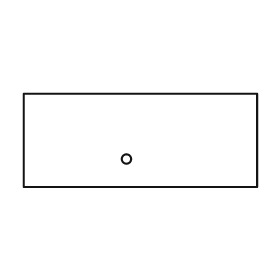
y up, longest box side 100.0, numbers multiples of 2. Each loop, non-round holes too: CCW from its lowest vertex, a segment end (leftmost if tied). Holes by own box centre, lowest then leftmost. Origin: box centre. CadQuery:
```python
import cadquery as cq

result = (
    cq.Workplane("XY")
    .moveTo(-50.0, -20.0)
    .lineTo(50.0, -20.0)
    .lineTo(50.0, 20.0)
    .lineTo(-50.0, 20.0)
    .close()
    .moveTo(-6.0, -8.0)
    .circle(2.0)
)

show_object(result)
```